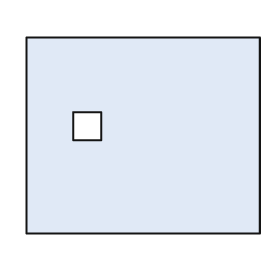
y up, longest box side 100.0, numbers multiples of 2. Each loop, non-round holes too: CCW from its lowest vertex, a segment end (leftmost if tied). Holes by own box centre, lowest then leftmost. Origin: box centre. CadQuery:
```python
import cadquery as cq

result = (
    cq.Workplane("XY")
    .moveTo(-50.0, -42.0)
    .lineTo(50.0, -42.0)
    .lineTo(50.0, 42.0)
    .lineTo(-50.0, 42.0)
    .close()
    .moveTo(-30.0, -2.0)
    .lineTo(-18.0, -2.0)
    .lineTo(-18.0, 10.0)
    .lineTo(-30.0, 10.0)
    .close()
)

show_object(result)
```